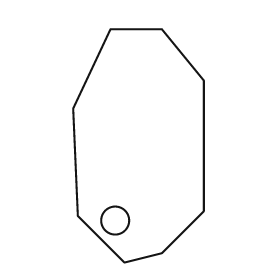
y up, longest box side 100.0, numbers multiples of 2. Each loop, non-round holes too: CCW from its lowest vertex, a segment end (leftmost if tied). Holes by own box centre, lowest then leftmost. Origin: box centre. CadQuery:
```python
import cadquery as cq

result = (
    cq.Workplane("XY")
    .moveTo(-6.0, -50.0)
    .lineTo(10.0, -46.0)
    .lineTo(28.0, -28.0)
    .lineTo(28.0, 28.0)
    .lineTo(10.0, 50.0)
    .lineTo(-12.0, 50.0)
    .lineTo(-28.0, 16.0)
    .lineTo(-26.0, -30.0)
    .close()
    .moveTo(-10.0, -32.0)
    .circle(6.0)
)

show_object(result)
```